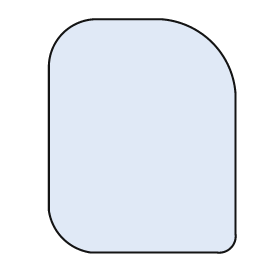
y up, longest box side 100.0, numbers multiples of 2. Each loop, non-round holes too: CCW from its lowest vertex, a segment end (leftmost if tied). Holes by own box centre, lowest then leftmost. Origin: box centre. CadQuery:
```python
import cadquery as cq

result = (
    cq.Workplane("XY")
    .moveTo(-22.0, -50.0)
    .lineTo(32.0, -50.0)
    .threePointArc((38.0, -48.0), (40.0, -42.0))
    .lineTo(40.0, 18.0)
    .threePointArc((30.0, 40.0), (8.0, 50.0))
    .lineTo(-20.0, 50.0)
    .threePointArc((-34.0, 44.0), (-40.0, 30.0))
    .lineTo(-40.0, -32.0)
    .threePointArc((-34.0, -44.0), (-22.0, -50.0))
    .close()
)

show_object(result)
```